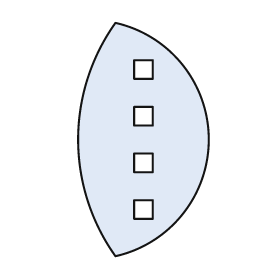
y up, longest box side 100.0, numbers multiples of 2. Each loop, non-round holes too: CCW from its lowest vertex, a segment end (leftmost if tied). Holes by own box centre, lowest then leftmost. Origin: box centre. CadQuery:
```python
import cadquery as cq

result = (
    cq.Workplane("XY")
    .moveTo(-12.0, -50.0)
    .threePointArc((28.0, 0.0), (-12.0, 50.0))
    .threePointArc((-28.0, 0.0), (-12.0, -50.0))
    .close()
    .moveTo(-4.0, -34.0)
    .lineTo(4.0, -34.0)
    .lineTo(4.0, -26.0)
    .lineTo(-4.0, -26.0)
    .close()
    .moveTo(-4.0, -14.0)
    .lineTo(4.0, -14.0)
    .lineTo(4.0, -6.0)
    .lineTo(-4.0, -6.0)
    .close()
    .moveTo(-4.0, 6.0)
    .lineTo(4.0, 6.0)
    .lineTo(4.0, 14.0)
    .lineTo(-4.0, 14.0)
    .close()
    .moveTo(-4.0, 26.0)
    .lineTo(4.0, 26.0)
    .lineTo(4.0, 34.0)
    .lineTo(-4.0, 34.0)
    .close()
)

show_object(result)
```